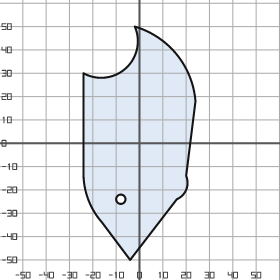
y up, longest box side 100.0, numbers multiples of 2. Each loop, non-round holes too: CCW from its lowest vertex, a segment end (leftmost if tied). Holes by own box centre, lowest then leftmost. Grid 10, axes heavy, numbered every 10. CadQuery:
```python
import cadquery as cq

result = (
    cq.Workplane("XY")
    .moveTo(-4.0, -50.0)
    .lineTo(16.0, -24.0)
    .threePointArc((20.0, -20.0), (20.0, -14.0))
    .lineTo(24.0, 18.0)
    .threePointArc((16.0, 38.0), (-2.0, 50.0))
    .threePointArc((-6.0, 32.0), (-24.0, 30.0))
    .lineTo(-24.0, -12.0)
    .threePointArc((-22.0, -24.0), (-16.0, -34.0))
    .close()
    .moveTo(-8.0, -24.0)
    .circle(2.0)
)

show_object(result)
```